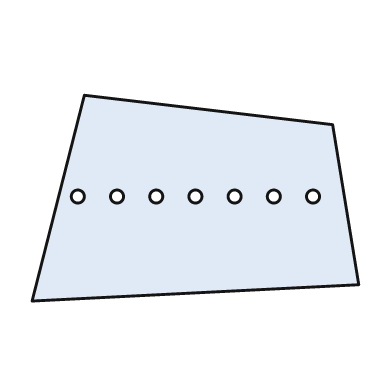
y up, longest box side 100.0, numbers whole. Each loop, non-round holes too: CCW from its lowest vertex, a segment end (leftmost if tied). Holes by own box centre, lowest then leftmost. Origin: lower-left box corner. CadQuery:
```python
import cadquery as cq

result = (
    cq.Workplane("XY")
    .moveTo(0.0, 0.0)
    .lineTo(100.0, 5.0)
    .lineTo(92.0, 54.0)
    .lineTo(16.0, 63.0)
    .close()
    .moveTo(14.0, 32.0)
    .circle(2.0)
    .moveTo(26.0, 32.0)
    .circle(2.0)
    .moveTo(38.0, 32.0)
    .circle(2.0)
    .moveTo(50.0, 32.0)
    .circle(2.0)
    .moveTo(62.0, 32.0)
    .circle(2.0)
    .moveTo(74.0, 32.0)
    .circle(2.0)
    .moveTo(86.0, 32.0)
    .circle(2.0)
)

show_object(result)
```